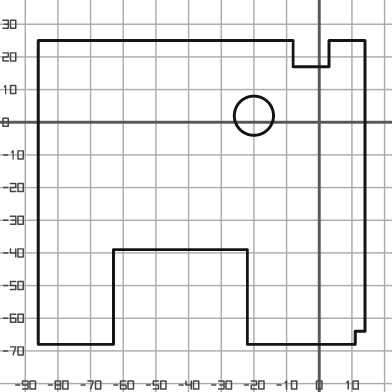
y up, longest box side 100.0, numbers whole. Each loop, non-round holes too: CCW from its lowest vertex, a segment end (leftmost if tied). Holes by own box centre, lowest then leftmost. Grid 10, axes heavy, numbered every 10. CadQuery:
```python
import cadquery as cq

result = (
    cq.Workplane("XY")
    .moveTo(-86.0, -68.0)
    .lineTo(-63.0, -68.0)
    .lineTo(-63.0, -39.0)
    .lineTo(-22.0, -39.0)
    .lineTo(-22.0, -68.0)
    .lineTo(11.0, -68.0)
    .lineTo(11.0, -64.0)
    .lineTo(14.0, -64.0)
    .lineTo(14.0, 25.0)
    .lineTo(3.0, 25.0)
    .lineTo(3.0, 17.0)
    .lineTo(-8.0, 17.0)
    .lineTo(-8.0, 25.0)
    .lineTo(-86.0, 25.0)
    .close()
    .moveTo(-20.0, 2.0)
    .circle(6.0)
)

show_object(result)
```